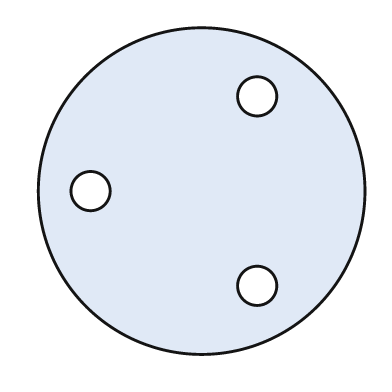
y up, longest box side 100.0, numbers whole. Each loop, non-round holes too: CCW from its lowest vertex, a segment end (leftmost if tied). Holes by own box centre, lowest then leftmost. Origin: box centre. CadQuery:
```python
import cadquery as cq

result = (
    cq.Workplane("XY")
    .moveTo(0.0, 0.0)
    .circle(50.0)
    .moveTo(17.0, -29.0)
    .circle(6.0)
    .moveTo(-34.0, 0.0)
    .circle(6.0)
    .moveTo(17.0, 29.0)
    .circle(6.0)
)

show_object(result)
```